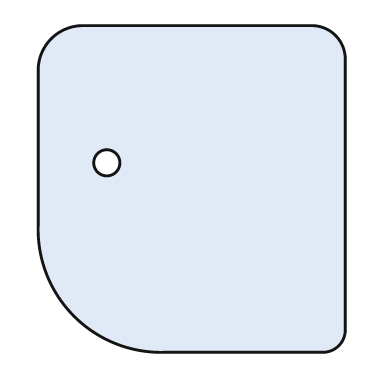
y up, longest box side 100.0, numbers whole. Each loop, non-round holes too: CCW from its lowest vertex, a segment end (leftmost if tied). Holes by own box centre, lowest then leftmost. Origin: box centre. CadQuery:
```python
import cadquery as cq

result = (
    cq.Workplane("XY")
    .moveTo(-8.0, -50.0)
    .lineTo(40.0, -50.0)
    .threePointArc((45.0, -48.0), (47.0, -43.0))
    .lineTo(47.0, 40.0)
    .threePointArc((44.0, 47.0), (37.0, 50.0))
    .lineTo(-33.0, 50.0)
    .threePointArc((-43.0, 46.0), (-47.0, 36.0))
    .lineTo(-47.0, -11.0)
    .threePointArc((-36.0, -39.0), (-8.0, -50.0))
    .close()
    .moveTo(-26.0, 8.0)
    .circle(4.0)
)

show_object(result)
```